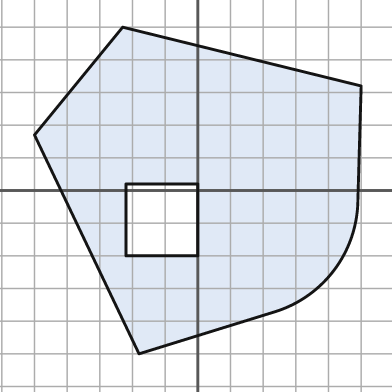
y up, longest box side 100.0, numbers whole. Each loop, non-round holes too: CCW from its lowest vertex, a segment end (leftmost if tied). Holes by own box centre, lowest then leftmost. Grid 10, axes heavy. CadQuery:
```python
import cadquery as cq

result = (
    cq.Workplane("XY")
    .moveTo(-18.0, -50.0)
    .lineTo(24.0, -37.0)
    .threePointArc((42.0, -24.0), (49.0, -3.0))
    .lineTo(50.0, 32.0)
    .lineTo(-23.0, 50.0)
    .lineTo(-50.0, 17.0)
    .close()
    .moveTo(-22.0, -20.0)
    .lineTo(0.0, -20.0)
    .lineTo(0.0, 2.0)
    .lineTo(-22.0, 2.0)
    .close()
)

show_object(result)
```